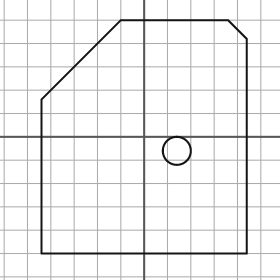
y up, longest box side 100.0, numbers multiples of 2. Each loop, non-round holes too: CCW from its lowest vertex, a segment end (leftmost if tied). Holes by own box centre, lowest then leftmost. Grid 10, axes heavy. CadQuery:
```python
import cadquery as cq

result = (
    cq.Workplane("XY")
    .moveTo(-44.0, -50.0)
    .lineTo(44.0, -50.0)
    .lineTo(44.0, 42.0)
    .lineTo(36.0, 50.0)
    .lineTo(-10.0, 50.0)
    .lineTo(-44.0, 16.0)
    .close()
    .moveTo(14.0, -6.0)
    .circle(6.0)
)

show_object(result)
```